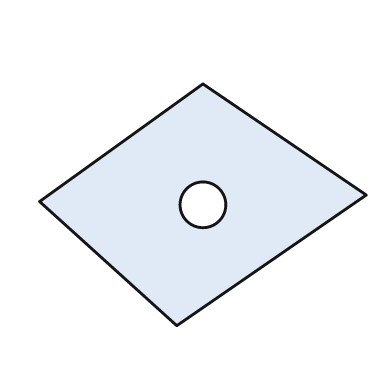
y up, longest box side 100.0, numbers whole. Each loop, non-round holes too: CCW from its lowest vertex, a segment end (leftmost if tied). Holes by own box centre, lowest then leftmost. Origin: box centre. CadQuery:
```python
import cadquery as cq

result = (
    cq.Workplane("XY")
    .moveTo(-8.0, -37.0)
    .lineTo(50.0, 3.0)
    .lineTo(0.0, 37.0)
    .lineTo(-50.0, 1.0)
    .close()
    .moveTo(0.0, 0.0)
    .circle(7.0)
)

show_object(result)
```